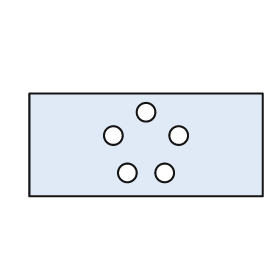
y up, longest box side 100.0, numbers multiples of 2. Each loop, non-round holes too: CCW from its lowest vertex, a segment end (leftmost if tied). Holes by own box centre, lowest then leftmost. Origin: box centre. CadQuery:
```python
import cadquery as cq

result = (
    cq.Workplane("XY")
    .moveTo(-50.0, -22.0)
    .lineTo(50.0, -22.0)
    .lineTo(50.0, 22.0)
    .lineTo(-50.0, 22.0)
    .close()
    .moveTo(-8.0, -12.0)
    .circle(4.0)
    .moveTo(8.0, -12.0)
    .circle(4.0)
    .moveTo(-14.0, 4.0)
    .circle(4.0)
    .moveTo(14.0, 4.0)
    .circle(4.0)
    .moveTo(0.0, 14.0)
    .circle(4.0)
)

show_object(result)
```